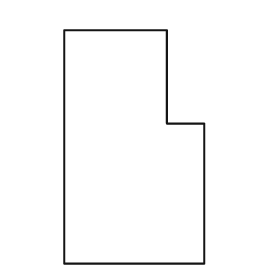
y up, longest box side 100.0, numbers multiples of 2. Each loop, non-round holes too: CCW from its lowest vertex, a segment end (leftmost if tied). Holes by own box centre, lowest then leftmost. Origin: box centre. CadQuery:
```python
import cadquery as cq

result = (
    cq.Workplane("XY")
    .moveTo(-30.0, -50.0)
    .lineTo(30.0, -50.0)
    .lineTo(30.0, 10.0)
    .lineTo(14.0, 10.0)
    .lineTo(14.0, 50.0)
    .lineTo(-30.0, 50.0)
    .close()
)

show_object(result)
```